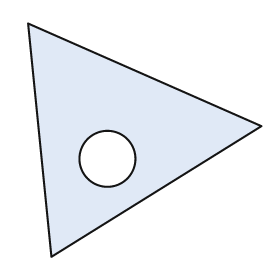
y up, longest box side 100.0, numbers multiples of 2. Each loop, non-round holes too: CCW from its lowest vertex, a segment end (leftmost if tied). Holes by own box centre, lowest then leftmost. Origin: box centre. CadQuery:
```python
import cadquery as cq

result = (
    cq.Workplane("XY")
    .moveTo(-40.0, -50.0)
    .lineTo(50.0, 6.0)
    .lineTo(-50.0, 50.0)
    .close()
    .moveTo(-16.0, -8.0)
    .circle(12.0)
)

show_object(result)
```